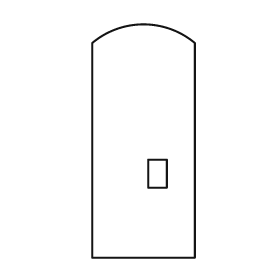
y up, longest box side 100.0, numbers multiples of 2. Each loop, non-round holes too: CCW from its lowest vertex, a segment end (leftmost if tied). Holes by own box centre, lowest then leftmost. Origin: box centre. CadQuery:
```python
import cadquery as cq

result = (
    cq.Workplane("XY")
    .moveTo(-22.0, -50.0)
    .lineTo(22.0, -50.0)
    .lineTo(22.0, 42.0)
    .threePointArc((0.0, 50.0), (-22.0, 42.0))
    .close()
    .moveTo(2.0, -20.0)
    .lineTo(10.0, -20.0)
    .lineTo(10.0, -8.0)
    .lineTo(2.0, -8.0)
    .close()
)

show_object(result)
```